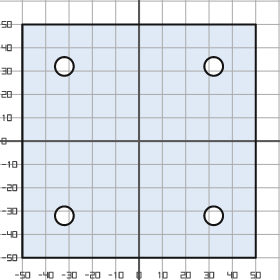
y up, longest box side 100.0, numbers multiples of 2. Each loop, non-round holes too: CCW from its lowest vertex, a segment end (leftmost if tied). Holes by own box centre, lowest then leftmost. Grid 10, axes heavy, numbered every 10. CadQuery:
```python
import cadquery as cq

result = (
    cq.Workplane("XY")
    .moveTo(-50.0, -50.0)
    .lineTo(50.0, -50.0)
    .lineTo(50.0, 50.0)
    .lineTo(-50.0, 50.0)
    .close()
    .moveTo(-32.0, -32.0)
    .circle(4.0)
    .moveTo(32.0, -32.0)
    .circle(4.0)
    .moveTo(-32.0, 32.0)
    .circle(4.0)
    .moveTo(32.0, 32.0)
    .circle(4.0)
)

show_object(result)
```